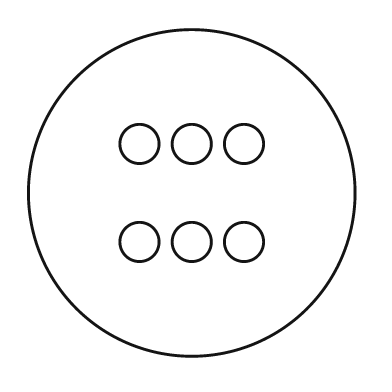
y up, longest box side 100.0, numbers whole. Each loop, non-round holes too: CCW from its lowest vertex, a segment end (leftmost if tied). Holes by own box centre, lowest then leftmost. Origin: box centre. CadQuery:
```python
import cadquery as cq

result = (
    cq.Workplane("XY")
    .moveTo(0.0, 0.0)
    .circle(50.0)
    .moveTo(-16.0, -15.0)
    .circle(6.0)
    .moveTo(0.0, -15.0)
    .circle(6.0)
    .moveTo(16.0, -15.0)
    .circle(6.0)
    .moveTo(-16.0, 15.0)
    .circle(6.0)
    .moveTo(0.0, 15.0)
    .circle(6.0)
    .moveTo(16.0, 15.0)
    .circle(6.0)
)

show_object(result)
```